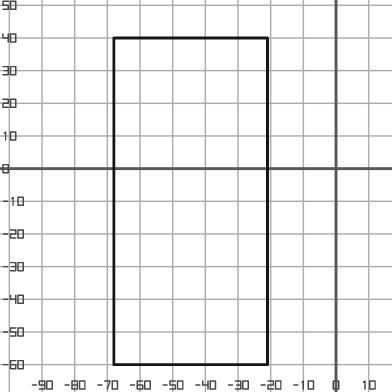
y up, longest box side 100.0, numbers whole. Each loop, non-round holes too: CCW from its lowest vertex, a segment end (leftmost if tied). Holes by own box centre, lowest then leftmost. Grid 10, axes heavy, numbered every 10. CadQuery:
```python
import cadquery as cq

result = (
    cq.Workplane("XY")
    .moveTo(-68.0, -60.0)
    .lineTo(-21.0, -60.0)
    .lineTo(-21.0, 40.0)
    .lineTo(-68.0, 40.0)
    .close()
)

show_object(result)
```